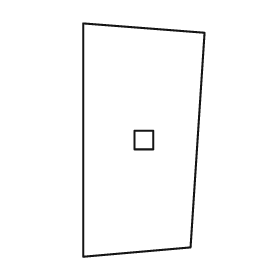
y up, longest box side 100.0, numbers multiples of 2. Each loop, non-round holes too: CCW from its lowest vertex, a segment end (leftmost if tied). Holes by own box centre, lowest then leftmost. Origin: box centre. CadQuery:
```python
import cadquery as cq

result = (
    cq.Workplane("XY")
    .moveTo(-26.0, -50.0)
    .lineTo(20.0, -46.0)
    .lineTo(26.0, 46.0)
    .lineTo(-26.0, 50.0)
    .close()
    .moveTo(-4.0, -4.0)
    .lineTo(4.0, -4.0)
    .lineTo(4.0, 4.0)
    .lineTo(-4.0, 4.0)
    .close()
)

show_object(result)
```